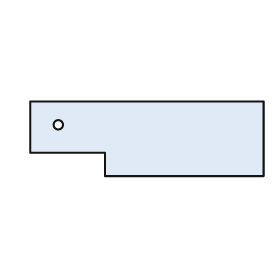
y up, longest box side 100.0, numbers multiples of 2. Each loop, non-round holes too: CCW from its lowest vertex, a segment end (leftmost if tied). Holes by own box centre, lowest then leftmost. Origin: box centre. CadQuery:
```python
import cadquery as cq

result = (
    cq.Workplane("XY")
    .moveTo(-18.0, -16.0)
    .lineTo(50.0, -16.0)
    .lineTo(50.0, 16.0)
    .lineTo(-50.0, 16.0)
    .lineTo(-50.0, -6.0)
    .lineTo(-18.0, -6.0)
    .close()
    .moveTo(-38.0, 6.0)
    .circle(2.0)
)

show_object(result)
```